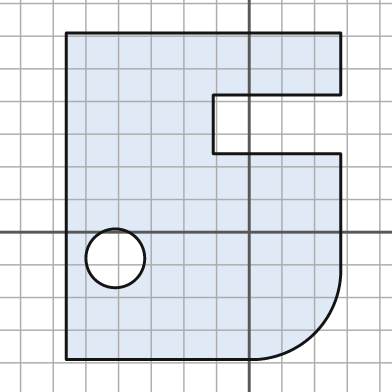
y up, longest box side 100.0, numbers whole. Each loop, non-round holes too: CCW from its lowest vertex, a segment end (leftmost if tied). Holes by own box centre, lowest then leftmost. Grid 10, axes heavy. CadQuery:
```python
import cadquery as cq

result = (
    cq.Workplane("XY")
    .moveTo(-56.0, -39.0)
    .lineTo(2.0, -39.0)
    .threePointArc((20.0, -31.0), (28.0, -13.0))
    .lineTo(28.0, 24.0)
    .lineTo(-11.0, 24.0)
    .lineTo(-11.0, 42.0)
    .lineTo(28.0, 42.0)
    .lineTo(28.0, 61.0)
    .lineTo(-56.0, 61.0)
    .close()
    .moveTo(-41.0, -8.0)
    .circle(9.0)
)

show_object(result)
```